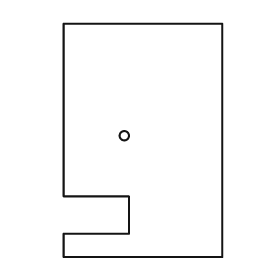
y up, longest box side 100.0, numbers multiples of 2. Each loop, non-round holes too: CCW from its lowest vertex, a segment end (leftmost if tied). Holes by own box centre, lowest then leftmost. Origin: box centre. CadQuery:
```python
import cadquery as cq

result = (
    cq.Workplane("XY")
    .moveTo(-34.0, -50.0)
    .lineTo(34.0, -50.0)
    .lineTo(34.0, 50.0)
    .lineTo(-34.0, 50.0)
    .lineTo(-34.0, -24.0)
    .lineTo(-6.0, -24.0)
    .lineTo(-6.0, -40.0)
    .lineTo(-34.0, -40.0)
    .close()
    .moveTo(-8.0, 2.0)
    .circle(2.0)
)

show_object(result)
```